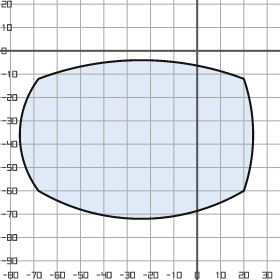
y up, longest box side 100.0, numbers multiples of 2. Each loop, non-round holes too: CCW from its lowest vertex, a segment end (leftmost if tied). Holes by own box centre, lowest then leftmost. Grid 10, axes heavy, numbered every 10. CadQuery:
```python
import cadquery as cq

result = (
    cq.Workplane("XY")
    .moveTo(-68.0, -60.0)
    .threePointArc((-24.0, -72.0), (20.0, -60.0))
    .threePointArc((24.0, -36.0), (20.0, -12.0))
    .threePointArc((-24.0, -4.0), (-68.0, -12.0))
    .threePointArc((-76.0, -36.0), (-68.0, -60.0))
    .close()
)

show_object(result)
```